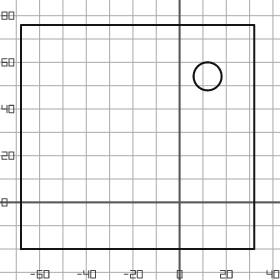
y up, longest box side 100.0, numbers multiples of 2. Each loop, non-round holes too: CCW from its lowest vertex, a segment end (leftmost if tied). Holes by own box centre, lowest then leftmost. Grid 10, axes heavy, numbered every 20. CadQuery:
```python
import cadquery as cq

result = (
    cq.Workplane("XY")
    .moveTo(-68.0, -20.0)
    .lineTo(32.0, -20.0)
    .lineTo(32.0, 76.0)
    .lineTo(-68.0, 76.0)
    .close()
    .moveTo(12.0, 54.0)
    .circle(6.0)
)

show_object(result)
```